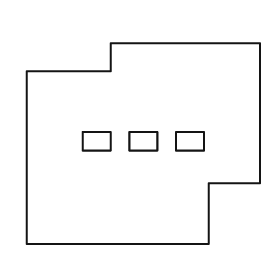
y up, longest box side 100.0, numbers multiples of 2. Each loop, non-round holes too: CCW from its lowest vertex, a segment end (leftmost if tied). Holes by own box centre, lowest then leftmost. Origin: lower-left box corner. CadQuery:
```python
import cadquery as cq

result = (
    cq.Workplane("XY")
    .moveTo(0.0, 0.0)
    .lineTo(78.0, 0.0)
    .lineTo(78.0, 26.0)
    .lineTo(100.0, 26.0)
    .lineTo(100.0, 86.0)
    .lineTo(36.0, 86.0)
    .lineTo(36.0, 74.0)
    .lineTo(0.0, 74.0)
    .close()
    .moveTo(24.0, 40.0)
    .lineTo(36.0, 40.0)
    .lineTo(36.0, 48.0)
    .lineTo(24.0, 48.0)
    .close()
    .moveTo(44.0, 40.0)
    .lineTo(56.0, 40.0)
    .lineTo(56.0, 48.0)
    .lineTo(44.0, 48.0)
    .close()
    .moveTo(64.0, 40.0)
    .lineTo(76.0, 40.0)
    .lineTo(76.0, 48.0)
    .lineTo(64.0, 48.0)
    .close()
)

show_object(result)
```